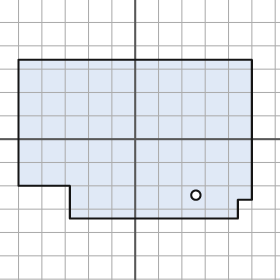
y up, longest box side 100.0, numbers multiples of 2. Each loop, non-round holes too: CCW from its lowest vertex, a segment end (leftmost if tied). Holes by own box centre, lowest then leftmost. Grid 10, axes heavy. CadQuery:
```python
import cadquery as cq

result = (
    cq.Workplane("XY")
    .moveTo(-28.0, -34.0)
    .lineTo(44.0, -34.0)
    .lineTo(44.0, -26.0)
    .lineTo(50.0, -26.0)
    .lineTo(50.0, 34.0)
    .lineTo(-50.0, 34.0)
    .lineTo(-50.0, -20.0)
    .lineTo(-28.0, -20.0)
    .close()
    .moveTo(26.0, -24.0)
    .circle(2.0)
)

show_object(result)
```